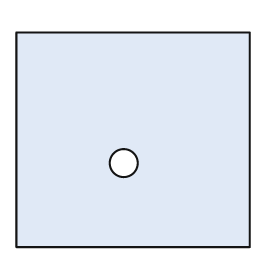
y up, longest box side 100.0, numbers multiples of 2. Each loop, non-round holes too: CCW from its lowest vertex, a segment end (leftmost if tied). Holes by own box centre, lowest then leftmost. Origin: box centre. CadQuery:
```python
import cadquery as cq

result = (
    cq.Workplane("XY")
    .moveTo(-50.0, -46.0)
    .lineTo(50.0, -46.0)
    .lineTo(50.0, 46.0)
    .lineTo(-50.0, 46.0)
    .close()
    .moveTo(-4.0, -10.0)
    .circle(6.0)
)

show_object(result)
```